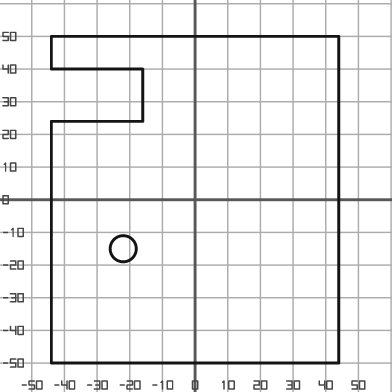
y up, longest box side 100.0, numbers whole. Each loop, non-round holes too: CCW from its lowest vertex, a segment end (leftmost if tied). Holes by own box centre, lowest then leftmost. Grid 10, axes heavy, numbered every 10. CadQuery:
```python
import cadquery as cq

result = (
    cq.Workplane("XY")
    .moveTo(-44.0, -50.0)
    .lineTo(44.0, -50.0)
    .lineTo(44.0, 50.0)
    .lineTo(-44.0, 50.0)
    .lineTo(-44.0, 40.0)
    .lineTo(-16.0, 40.0)
    .lineTo(-16.0, 24.0)
    .lineTo(-44.0, 24.0)
    .close()
    .moveTo(-22.0, -15.0)
    .circle(4.0)
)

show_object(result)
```